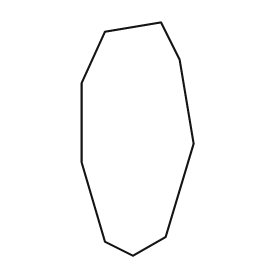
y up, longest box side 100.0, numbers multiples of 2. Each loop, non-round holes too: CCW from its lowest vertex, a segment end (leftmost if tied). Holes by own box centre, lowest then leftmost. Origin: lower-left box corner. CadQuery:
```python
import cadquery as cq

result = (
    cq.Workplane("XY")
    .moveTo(22.0, 0.0)
    .lineTo(36.0, 8.0)
    .lineTo(48.0, 48.0)
    .lineTo(42.0, 84.0)
    .lineTo(34.0, 100.0)
    .lineTo(10.0, 96.0)
    .lineTo(0.0, 74.0)
    .lineTo(0.0, 40.0)
    .lineTo(10.0, 6.0)
    .close()
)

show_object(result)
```